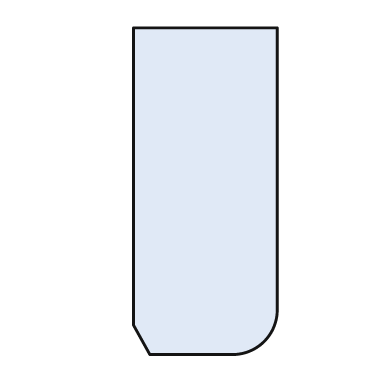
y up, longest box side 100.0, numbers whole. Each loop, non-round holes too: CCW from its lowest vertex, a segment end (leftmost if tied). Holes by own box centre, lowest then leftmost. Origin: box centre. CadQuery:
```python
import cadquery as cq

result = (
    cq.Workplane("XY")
    .moveTo(-17.0, -50.0)
    .lineTo(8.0, -50.0)
    .threePointArc((18.0, -46.0), (22.0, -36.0))
    .lineTo(22.0, 50.0)
    .lineTo(-22.0, 50.0)
    .lineTo(-22.0, -41.0)
    .close()
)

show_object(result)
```